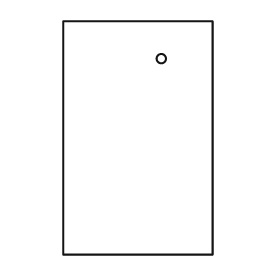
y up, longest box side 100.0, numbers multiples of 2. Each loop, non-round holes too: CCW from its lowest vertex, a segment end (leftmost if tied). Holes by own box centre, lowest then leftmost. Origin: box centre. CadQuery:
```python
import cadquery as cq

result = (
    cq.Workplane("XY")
    .moveTo(-32.0, -50.0)
    .lineTo(32.0, -50.0)
    .lineTo(32.0, 50.0)
    .lineTo(-32.0, 50.0)
    .close()
    .moveTo(10.0, 34.0)
    .circle(2.0)
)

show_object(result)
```